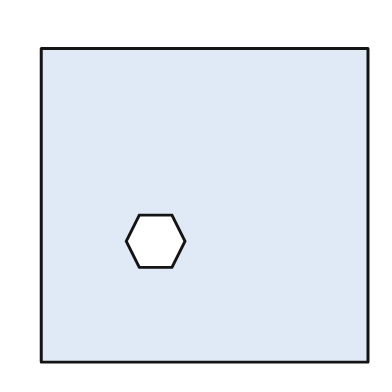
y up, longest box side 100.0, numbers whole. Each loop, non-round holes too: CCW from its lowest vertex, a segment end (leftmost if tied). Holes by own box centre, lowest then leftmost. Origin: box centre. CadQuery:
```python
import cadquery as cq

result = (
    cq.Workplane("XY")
    .moveTo(-50.0, -48.0)
    .lineTo(50.0, -48.0)
    .lineTo(50.0, 48.0)
    .lineTo(-50.0, 48.0)
    .close()
    .moveTo(-20.0, -19.0)
    .lineTo(-10.0, -19.0)
    .lineTo(-6.0, -11.0)
    .lineTo(-10.0, -3.0)
    .lineTo(-20.0, -3.0)
    .lineTo(-24.0, -11.0)
    .close()
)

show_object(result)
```